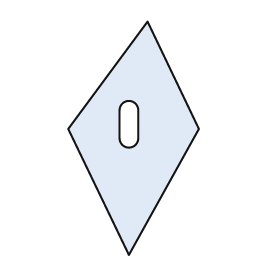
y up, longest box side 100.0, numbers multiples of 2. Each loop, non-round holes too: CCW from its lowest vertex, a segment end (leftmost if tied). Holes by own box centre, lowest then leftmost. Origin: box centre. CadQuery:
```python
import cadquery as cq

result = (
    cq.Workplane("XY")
    .moveTo(-2.0, -50.0)
    .lineTo(28.0, 4.0)
    .lineTo(6.0, 50.0)
    .lineTo(-28.0, 4.0)
    .close()
    .moveTo(-6.0, 0.0)
    .threePointArc((-2.0, -4.0), (2.0, 0.0))
    .lineTo(2.0, 12.0)
    .threePointArc((-2.0, 16.0), (-6.0, 12.0))
    .close()
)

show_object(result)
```